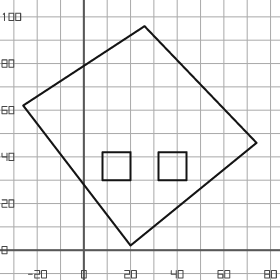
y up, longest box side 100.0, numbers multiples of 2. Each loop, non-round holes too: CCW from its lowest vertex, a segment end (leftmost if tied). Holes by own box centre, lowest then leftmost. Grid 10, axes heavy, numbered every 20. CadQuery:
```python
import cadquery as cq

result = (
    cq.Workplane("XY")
    .moveTo(20.0, 2.0)
    .lineTo(74.0, 46.0)
    .lineTo(26.0, 96.0)
    .lineTo(-26.0, 62.0)
    .close()
    .moveTo(8.0, 30.0)
    .lineTo(20.0, 30.0)
    .lineTo(20.0, 42.0)
    .lineTo(8.0, 42.0)
    .close()
    .moveTo(32.0, 30.0)
    .lineTo(44.0, 30.0)
    .lineTo(44.0, 42.0)
    .lineTo(32.0, 42.0)
    .close()
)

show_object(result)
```